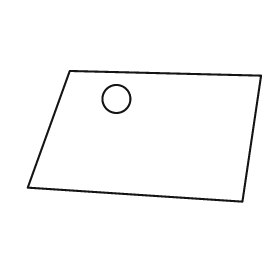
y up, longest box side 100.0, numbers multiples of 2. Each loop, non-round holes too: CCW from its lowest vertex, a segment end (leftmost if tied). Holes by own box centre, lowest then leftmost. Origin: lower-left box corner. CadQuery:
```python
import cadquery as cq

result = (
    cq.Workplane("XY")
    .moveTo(92.0, 0.0)
    .lineTo(100.0, 54.0)
    .lineTo(18.0, 56.0)
    .lineTo(0.0, 6.0)
    .close()
    .moveTo(38.0, 44.0)
    .circle(6.0)
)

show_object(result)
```